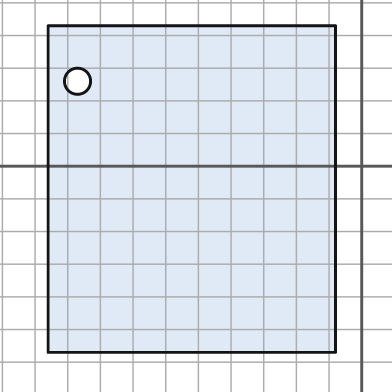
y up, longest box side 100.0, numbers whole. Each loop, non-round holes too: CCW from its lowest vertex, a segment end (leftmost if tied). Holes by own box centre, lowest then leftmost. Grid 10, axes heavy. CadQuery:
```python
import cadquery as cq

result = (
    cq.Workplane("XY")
    .moveTo(-96.0, -57.0)
    .lineTo(-8.0, -57.0)
    .lineTo(-8.0, 43.0)
    .lineTo(-96.0, 43.0)
    .close()
    .moveTo(-87.0, 26.0)
    .circle(4.0)
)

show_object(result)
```